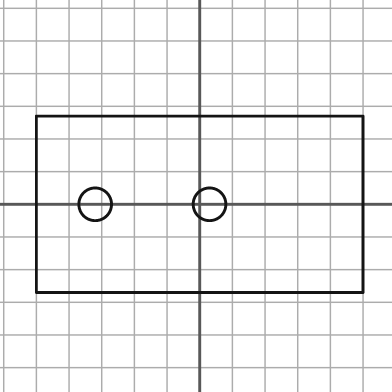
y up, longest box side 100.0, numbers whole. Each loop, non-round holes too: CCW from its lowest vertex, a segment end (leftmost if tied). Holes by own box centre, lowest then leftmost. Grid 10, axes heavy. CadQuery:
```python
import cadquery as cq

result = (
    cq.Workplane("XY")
    .moveTo(-50.0, -27.0)
    .lineTo(50.0, -27.0)
    .lineTo(50.0, 27.0)
    .lineTo(-50.0, 27.0)
    .close()
    .moveTo(-32.0, 0.0)
    .circle(5.0)
    .moveTo(3.0, 0.0)
    .circle(5.0)
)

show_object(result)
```